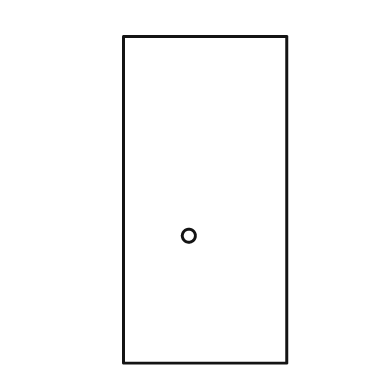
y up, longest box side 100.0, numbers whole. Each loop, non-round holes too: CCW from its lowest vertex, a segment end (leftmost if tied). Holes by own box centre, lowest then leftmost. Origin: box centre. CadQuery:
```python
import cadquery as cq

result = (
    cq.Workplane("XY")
    .moveTo(-25.0, -50.0)
    .lineTo(25.0, -50.0)
    .lineTo(25.0, 50.0)
    .lineTo(-25.0, 50.0)
    .close()
    .moveTo(-5.0, -11.0)
    .circle(2.0)
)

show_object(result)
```